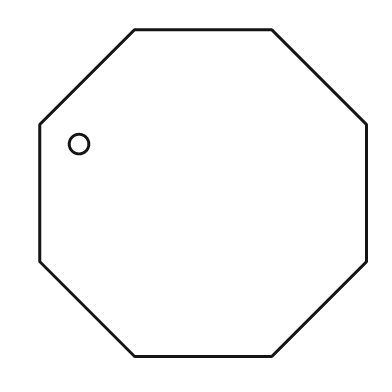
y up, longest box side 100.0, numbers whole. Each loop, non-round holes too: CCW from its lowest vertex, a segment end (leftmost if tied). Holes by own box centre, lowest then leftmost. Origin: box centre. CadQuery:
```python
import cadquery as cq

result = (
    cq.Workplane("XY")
    .moveTo(-21.0, -50.0)
    .lineTo(21.0, -50.0)
    .lineTo(50.0, -21.0)
    .lineTo(50.0, 21.0)
    .lineTo(21.0, 50.0)
    .lineTo(-21.0, 50.0)
    .lineTo(-50.0, 21.0)
    .lineTo(-50.0, -21.0)
    .close()
    .moveTo(-38.0, 15.0)
    .circle(3.0)
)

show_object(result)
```